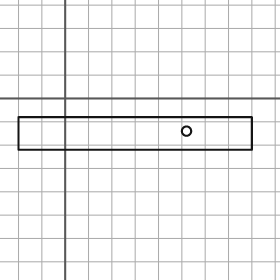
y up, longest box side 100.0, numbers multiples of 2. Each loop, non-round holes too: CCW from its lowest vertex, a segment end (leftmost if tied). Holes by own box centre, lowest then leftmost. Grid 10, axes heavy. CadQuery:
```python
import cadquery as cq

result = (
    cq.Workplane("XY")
    .moveTo(-20.0, -22.0)
    .lineTo(80.0, -22.0)
    .lineTo(80.0, -8.0)
    .lineTo(-20.0, -8.0)
    .close()
    .moveTo(52.0, -14.0)
    .circle(2.0)
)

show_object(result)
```